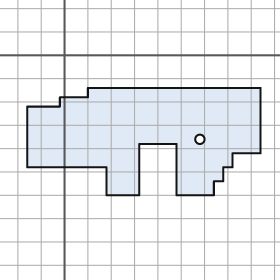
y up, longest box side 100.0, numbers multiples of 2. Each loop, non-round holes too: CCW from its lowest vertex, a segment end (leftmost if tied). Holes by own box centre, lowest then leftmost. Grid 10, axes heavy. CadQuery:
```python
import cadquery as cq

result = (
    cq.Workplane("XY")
    .moveTo(18.0, -60.0)
    .lineTo(32.0, -60.0)
    .lineTo(32.0, -38.0)
    .lineTo(48.0, -38.0)
    .lineTo(48.0, -60.0)
    .lineTo(64.0, -60.0)
    .lineTo(64.0, -54.0)
    .lineTo(68.0, -54.0)
    .lineTo(68.0, -48.0)
    .lineTo(72.0, -48.0)
    .lineTo(72.0, -42.0)
    .lineTo(84.0, -42.0)
    .lineTo(84.0, -14.0)
    .lineTo(10.0, -14.0)
    .lineTo(10.0, -18.0)
    .lineTo(-2.0, -18.0)
    .lineTo(-2.0, -22.0)
    .lineTo(-16.0, -22.0)
    .lineTo(-16.0, -48.0)
    .lineTo(18.0, -48.0)
    .close()
    .moveTo(58.0, -36.0)
    .circle(2.0)
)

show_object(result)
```